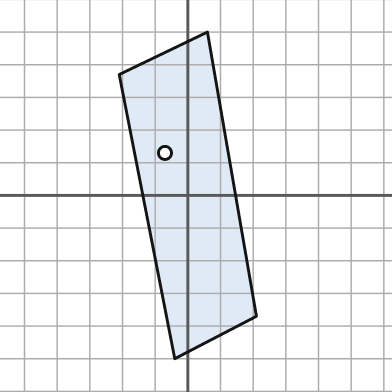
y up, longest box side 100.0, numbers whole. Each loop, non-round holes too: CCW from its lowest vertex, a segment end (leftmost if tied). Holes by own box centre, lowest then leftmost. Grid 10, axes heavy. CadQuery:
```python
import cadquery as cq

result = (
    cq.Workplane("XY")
    .moveTo(-4.0, -50.0)
    .lineTo(21.0, -37.0)
    .lineTo(6.0, 50.0)
    .lineTo(-21.0, 37.0)
    .close()
    .moveTo(-7.0, 13.0)
    .circle(2.0)
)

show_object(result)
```